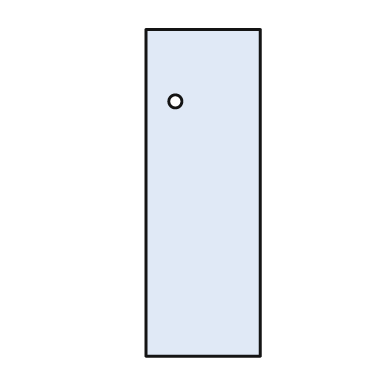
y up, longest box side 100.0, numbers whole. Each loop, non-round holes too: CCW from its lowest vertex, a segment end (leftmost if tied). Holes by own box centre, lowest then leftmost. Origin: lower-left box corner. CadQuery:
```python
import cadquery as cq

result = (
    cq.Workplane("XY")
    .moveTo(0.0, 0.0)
    .lineTo(35.0, 0.0)
    .lineTo(35.0, 100.0)
    .lineTo(0.0, 100.0)
    .close()
    .moveTo(9.0, 78.0)
    .circle(2.0)
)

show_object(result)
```